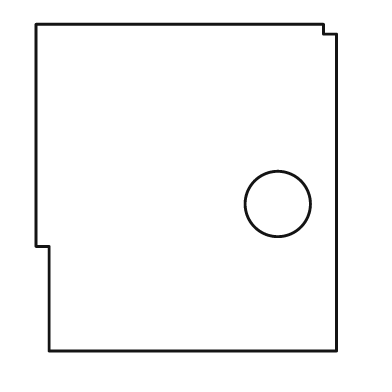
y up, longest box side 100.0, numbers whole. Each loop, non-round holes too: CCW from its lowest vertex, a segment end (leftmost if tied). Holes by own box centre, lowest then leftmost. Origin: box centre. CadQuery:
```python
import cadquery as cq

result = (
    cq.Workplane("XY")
    .moveTo(-42.0, -50.0)
    .lineTo(46.0, -50.0)
    .lineTo(46.0, 47.0)
    .lineTo(42.0, 47.0)
    .lineTo(42.0, 50.0)
    .lineTo(-46.0, 50.0)
    .lineTo(-46.0, -18.0)
    .lineTo(-42.0, -18.0)
    .close()
    .moveTo(28.0, -5.0)
    .circle(10.0)
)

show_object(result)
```